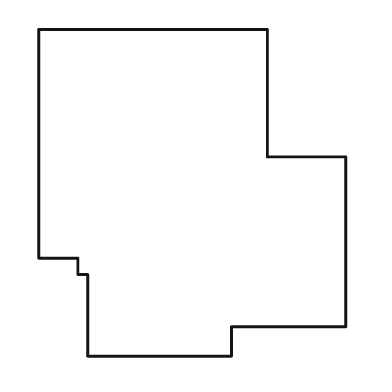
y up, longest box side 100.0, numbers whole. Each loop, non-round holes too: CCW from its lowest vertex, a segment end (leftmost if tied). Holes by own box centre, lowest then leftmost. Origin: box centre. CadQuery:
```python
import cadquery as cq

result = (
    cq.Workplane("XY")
    .moveTo(-32.0, -50.0)
    .lineTo(12.0, -50.0)
    .lineTo(12.0, -41.0)
    .lineTo(47.0, -41.0)
    .lineTo(47.0, 11.0)
    .lineTo(23.0, 11.0)
    .lineTo(23.0, 50.0)
    .lineTo(-47.0, 50.0)
    .lineTo(-47.0, -20.0)
    .lineTo(-35.0, -20.0)
    .lineTo(-35.0, -25.0)
    .lineTo(-32.0, -25.0)
    .close()
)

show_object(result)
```